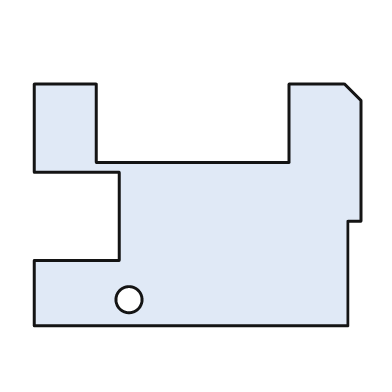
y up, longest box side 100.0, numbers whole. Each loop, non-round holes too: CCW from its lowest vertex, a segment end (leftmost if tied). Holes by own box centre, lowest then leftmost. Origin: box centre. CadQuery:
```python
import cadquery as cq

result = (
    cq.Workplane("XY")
    .moveTo(-50.0, -37.0)
    .lineTo(46.0, -37.0)
    .lineTo(46.0, -5.0)
    .lineTo(50.0, -5.0)
    .lineTo(50.0, 32.0)
    .lineTo(45.0, 37.0)
    .lineTo(28.0, 37.0)
    .lineTo(28.0, 13.0)
    .lineTo(-31.0, 13.0)
    .lineTo(-31.0, 37.0)
    .lineTo(-50.0, 37.0)
    .lineTo(-50.0, 10.0)
    .lineTo(-24.0, 10.0)
    .lineTo(-24.0, -17.0)
    .lineTo(-50.0, -17.0)
    .close()
    .moveTo(-21.0, -29.0)
    .circle(4.0)
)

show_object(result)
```